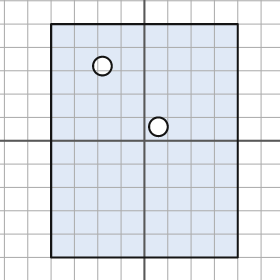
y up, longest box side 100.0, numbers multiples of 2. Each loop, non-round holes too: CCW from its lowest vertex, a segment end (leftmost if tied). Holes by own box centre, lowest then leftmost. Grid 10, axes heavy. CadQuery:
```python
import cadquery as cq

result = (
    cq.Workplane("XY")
    .moveTo(-40.0, -50.0)
    .lineTo(40.0, -50.0)
    .lineTo(40.0, 50.0)
    .lineTo(-40.0, 50.0)
    .close()
    .moveTo(6.0, 6.0)
    .circle(4.0)
    .moveTo(-18.0, 32.0)
    .circle(4.0)
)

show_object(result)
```